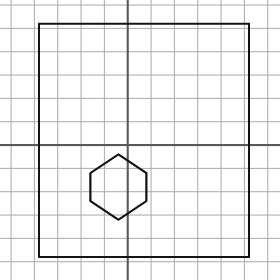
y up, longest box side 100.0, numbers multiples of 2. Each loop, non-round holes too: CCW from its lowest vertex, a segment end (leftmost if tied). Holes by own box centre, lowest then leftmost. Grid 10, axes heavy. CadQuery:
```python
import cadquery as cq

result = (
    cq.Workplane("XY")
    .moveTo(-38.0, -48.0)
    .lineTo(52.0, -48.0)
    .lineTo(52.0, 52.0)
    .lineTo(-38.0, 52.0)
    .close()
    .moveTo(-4.0, -32.0)
    .lineTo(8.0, -24.0)
    .lineTo(8.0, -12.0)
    .lineTo(-4.0, -4.0)
    .lineTo(-16.0, -12.0)
    .lineTo(-16.0, -24.0)
    .close()
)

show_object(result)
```